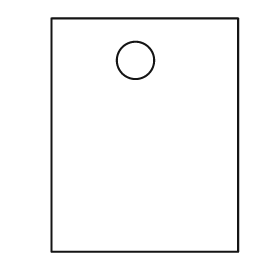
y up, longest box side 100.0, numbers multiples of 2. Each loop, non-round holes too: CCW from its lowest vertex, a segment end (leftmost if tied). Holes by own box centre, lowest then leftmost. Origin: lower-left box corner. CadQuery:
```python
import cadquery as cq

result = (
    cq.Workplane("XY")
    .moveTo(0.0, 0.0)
    .lineTo(80.0, 0.0)
    .lineTo(80.0, 100.0)
    .lineTo(0.0, 100.0)
    .close()
    .moveTo(36.0, 82.0)
    .circle(8.0)
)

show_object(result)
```